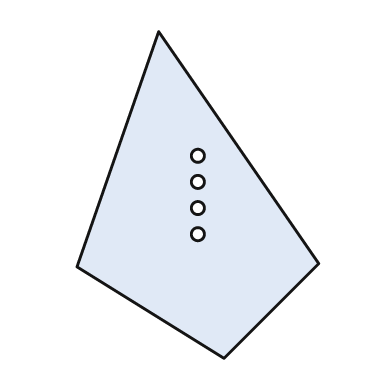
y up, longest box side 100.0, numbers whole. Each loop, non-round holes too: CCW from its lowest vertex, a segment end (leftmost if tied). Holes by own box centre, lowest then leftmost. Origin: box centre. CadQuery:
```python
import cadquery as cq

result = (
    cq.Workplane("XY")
    .moveTo(8.0, -50.0)
    .lineTo(37.0, -21.0)
    .lineTo(-12.0, 50.0)
    .lineTo(-37.0, -22.0)
    .close()
    .moveTo(0.0, -12.0)
    .circle(2.0)
    .moveTo(0.0, -4.0)
    .circle(2.0)
    .moveTo(0.0, 4.0)
    .circle(2.0)
    .moveTo(0.0, 12.0)
    .circle(2.0)
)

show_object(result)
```